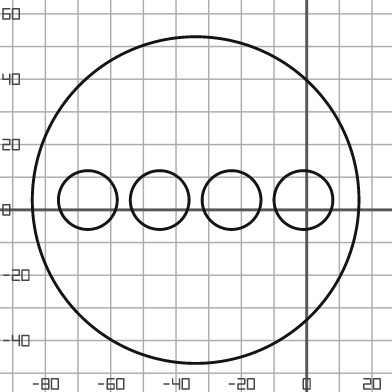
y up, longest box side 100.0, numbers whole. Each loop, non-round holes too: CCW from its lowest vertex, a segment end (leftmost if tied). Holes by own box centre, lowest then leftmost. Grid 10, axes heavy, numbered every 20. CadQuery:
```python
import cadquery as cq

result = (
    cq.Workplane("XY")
    .moveTo(-34.0, 3.0)
    .circle(50.0)
    .moveTo(-67.0, 3.0)
    .circle(9.0)
    .moveTo(-45.0, 3.0)
    .circle(9.0)
    .moveTo(-23.0, 3.0)
    .circle(9.0)
    .moveTo(-1.0, 3.0)
    .circle(9.0)
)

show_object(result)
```